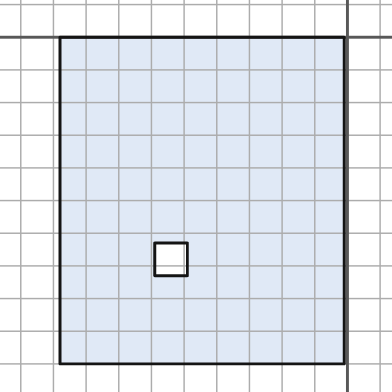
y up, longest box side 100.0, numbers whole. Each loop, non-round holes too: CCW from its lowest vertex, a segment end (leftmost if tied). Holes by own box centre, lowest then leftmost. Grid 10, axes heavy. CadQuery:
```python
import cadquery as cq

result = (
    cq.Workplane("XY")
    .moveTo(-88.0, -100.0)
    .lineTo(-1.0, -100.0)
    .lineTo(-1.0, 0.0)
    .lineTo(-88.0, 0.0)
    .close()
    .moveTo(-59.0, -73.0)
    .lineTo(-49.0, -73.0)
    .lineTo(-49.0, -63.0)
    .lineTo(-59.0, -63.0)
    .close()
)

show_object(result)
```